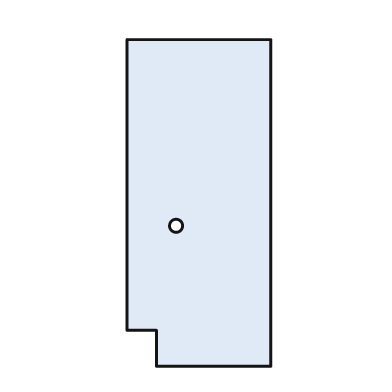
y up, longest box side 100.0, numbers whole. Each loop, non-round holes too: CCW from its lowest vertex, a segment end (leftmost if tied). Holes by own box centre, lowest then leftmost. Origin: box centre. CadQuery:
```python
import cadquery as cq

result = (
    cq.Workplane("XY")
    .moveTo(-13.0, -50.0)
    .lineTo(22.0, -50.0)
    .lineTo(22.0, 50.0)
    .lineTo(-22.0, 50.0)
    .lineTo(-22.0, -39.0)
    .lineTo(-13.0, -39.0)
    .close()
    .moveTo(-7.0, -7.0)
    .circle(2.0)
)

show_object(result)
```